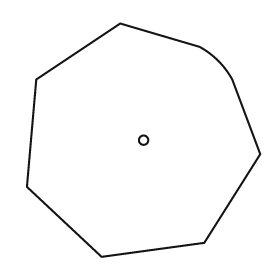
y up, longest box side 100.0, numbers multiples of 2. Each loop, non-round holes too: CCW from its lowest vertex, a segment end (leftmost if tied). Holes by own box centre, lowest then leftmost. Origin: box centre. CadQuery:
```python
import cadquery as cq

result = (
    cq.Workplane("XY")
    .moveTo(-18.0, -50.0)
    .lineTo(26.0, -44.0)
    .lineTo(50.0, -6.0)
    .lineTo(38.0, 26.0)
    .threePointArc((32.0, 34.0), (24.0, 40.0))
    .lineTo(-10.0, 50.0)
    .lineTo(-46.0, 26.0)
    .lineTo(-50.0, -20.0)
    .close()
    .moveTo(0.0, 0.0)
    .circle(2.0)
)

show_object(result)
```